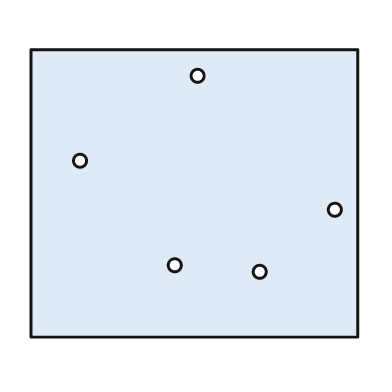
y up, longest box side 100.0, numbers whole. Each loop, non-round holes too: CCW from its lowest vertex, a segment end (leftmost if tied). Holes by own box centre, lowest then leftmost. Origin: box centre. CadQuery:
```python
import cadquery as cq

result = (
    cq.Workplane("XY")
    .moveTo(-50.0, -44.0)
    .lineTo(50.0, -44.0)
    .lineTo(50.0, 44.0)
    .lineTo(-50.0, 44.0)
    .close()
    .moveTo(20.0, -24.0)
    .circle(2.0)
    .moveTo(-6.0, -22.0)
    .circle(2.0)
    .moveTo(43.0, -5.0)
    .circle(2.0)
    .moveTo(-35.0, 10.0)
    .circle(2.0)
    .moveTo(1.0, 36.0)
    .circle(2.0)
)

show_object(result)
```